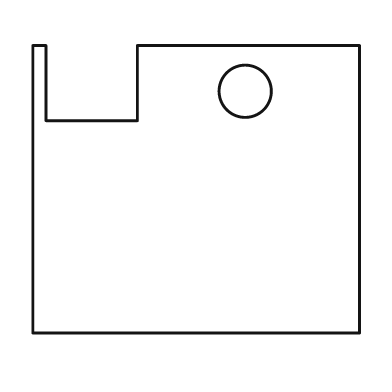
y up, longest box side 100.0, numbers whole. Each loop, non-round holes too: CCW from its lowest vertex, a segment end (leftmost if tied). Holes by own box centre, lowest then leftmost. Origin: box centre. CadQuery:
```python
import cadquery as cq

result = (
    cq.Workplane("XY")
    .moveTo(-50.0, -44.0)
    .lineTo(50.0, -44.0)
    .lineTo(50.0, 44.0)
    .lineTo(-18.0, 44.0)
    .lineTo(-18.0, 21.0)
    .lineTo(-46.0, 21.0)
    .lineTo(-46.0, 44.0)
    .lineTo(-50.0, 44.0)
    .close()
    .moveTo(15.0, 30.0)
    .circle(8.0)
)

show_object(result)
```